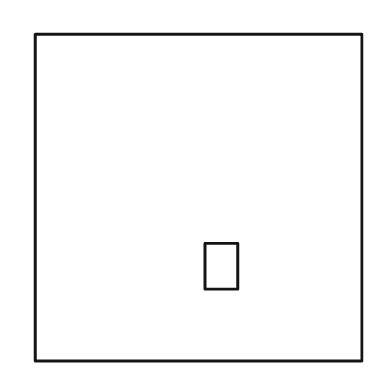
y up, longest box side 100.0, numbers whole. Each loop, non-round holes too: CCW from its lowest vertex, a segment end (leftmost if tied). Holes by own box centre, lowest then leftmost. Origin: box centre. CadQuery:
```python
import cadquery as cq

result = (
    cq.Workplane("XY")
    .moveTo(-50.0, -50.0)
    .lineTo(50.0, -50.0)
    .lineTo(50.0, 50.0)
    .lineTo(-50.0, 50.0)
    .close()
    .moveTo(2.0, -28.0)
    .lineTo(12.0, -28.0)
    .lineTo(12.0, -14.0)
    .lineTo(2.0, -14.0)
    .close()
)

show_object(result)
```